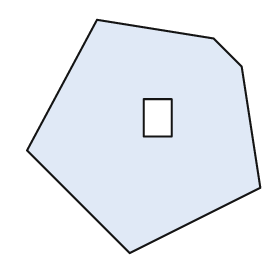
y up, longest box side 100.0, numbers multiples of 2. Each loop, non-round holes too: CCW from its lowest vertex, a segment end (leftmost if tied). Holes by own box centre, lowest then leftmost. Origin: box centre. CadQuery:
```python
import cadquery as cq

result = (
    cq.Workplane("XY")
    .moveTo(-6.0, -50.0)
    .lineTo(50.0, -22.0)
    .lineTo(42.0, 30.0)
    .lineTo(30.0, 42.0)
    .lineTo(-20.0, 50.0)
    .lineTo(-50.0, -6.0)
    .close()
    .moveTo(0.0, 0.0)
    .lineTo(12.0, 0.0)
    .lineTo(12.0, 16.0)
    .lineTo(0.0, 16.0)
    .close()
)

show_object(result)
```